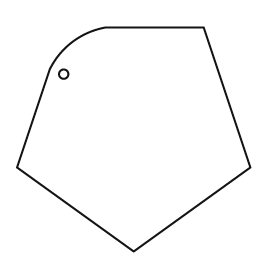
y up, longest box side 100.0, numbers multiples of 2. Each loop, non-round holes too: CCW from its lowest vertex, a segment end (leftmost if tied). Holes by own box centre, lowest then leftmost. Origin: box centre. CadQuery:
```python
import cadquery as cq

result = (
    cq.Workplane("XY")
    .moveTo(0.0, -48.0)
    .lineTo(50.0, -12.0)
    .lineTo(30.0, 48.0)
    .lineTo(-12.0, 48.0)
    .threePointArc((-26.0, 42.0), (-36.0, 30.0))
    .lineTo(-50.0, -12.0)
    .close()
    .moveTo(-30.0, 28.0)
    .circle(2.0)
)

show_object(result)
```